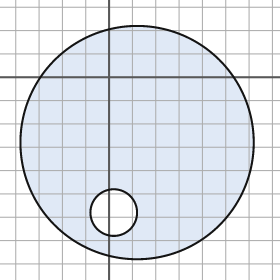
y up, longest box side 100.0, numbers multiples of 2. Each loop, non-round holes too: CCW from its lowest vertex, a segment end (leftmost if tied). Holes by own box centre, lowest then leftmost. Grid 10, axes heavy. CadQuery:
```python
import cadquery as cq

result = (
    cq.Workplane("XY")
    .moveTo(12.0, -28.0)
    .circle(50.0)
    .moveTo(2.0, -58.0)
    .circle(10.0)
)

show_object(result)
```